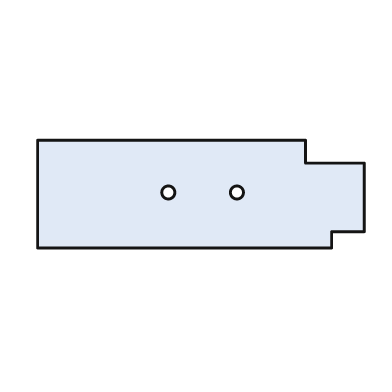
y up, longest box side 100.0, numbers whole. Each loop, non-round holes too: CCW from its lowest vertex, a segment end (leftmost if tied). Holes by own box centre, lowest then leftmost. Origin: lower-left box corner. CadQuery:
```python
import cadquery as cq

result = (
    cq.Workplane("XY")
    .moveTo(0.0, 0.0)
    .lineTo(90.0, 0.0)
    .lineTo(90.0, 5.0)
    .lineTo(100.0, 5.0)
    .lineTo(100.0, 26.0)
    .lineTo(82.0, 26.0)
    .lineTo(82.0, 33.0)
    .lineTo(0.0, 33.0)
    .close()
    .moveTo(40.0, 17.0)
    .circle(2.0)
    .moveTo(61.0, 17.0)
    .circle(2.0)
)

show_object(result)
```